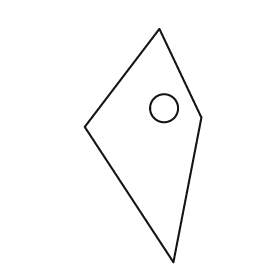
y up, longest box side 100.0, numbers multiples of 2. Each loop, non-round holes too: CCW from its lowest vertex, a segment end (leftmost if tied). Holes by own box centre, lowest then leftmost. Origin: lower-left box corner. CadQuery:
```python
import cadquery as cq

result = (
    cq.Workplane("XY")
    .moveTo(38.0, 0.0)
    .lineTo(50.0, 62.0)
    .lineTo(32.0, 100.0)
    .lineTo(0.0, 58.0)
    .close()
    .moveTo(34.0, 66.0)
    .circle(6.0)
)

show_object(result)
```